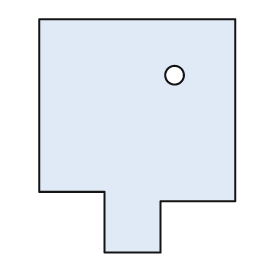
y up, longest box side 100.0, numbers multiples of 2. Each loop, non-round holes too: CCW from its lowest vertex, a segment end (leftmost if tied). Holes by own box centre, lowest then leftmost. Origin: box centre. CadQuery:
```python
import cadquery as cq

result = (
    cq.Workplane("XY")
    .moveTo(-14.0, -50.0)
    .lineTo(10.0, -50.0)
    .lineTo(10.0, -28.0)
    .lineTo(42.0, -28.0)
    .lineTo(42.0, 50.0)
    .lineTo(-42.0, 50.0)
    .lineTo(-42.0, -24.0)
    .lineTo(-14.0, -24.0)
    .close()
    .moveTo(16.0, 26.0)
    .circle(4.0)
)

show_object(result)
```